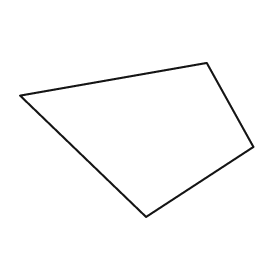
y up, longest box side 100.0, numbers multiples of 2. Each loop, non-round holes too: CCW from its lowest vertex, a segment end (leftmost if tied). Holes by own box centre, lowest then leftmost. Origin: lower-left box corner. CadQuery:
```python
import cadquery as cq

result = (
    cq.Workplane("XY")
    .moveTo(54.0, 0.0)
    .lineTo(100.0, 30.0)
    .lineTo(80.0, 66.0)
    .lineTo(0.0, 52.0)
    .close()
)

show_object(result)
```